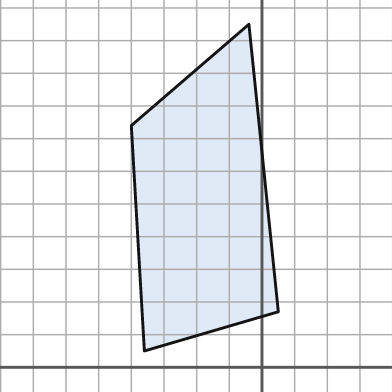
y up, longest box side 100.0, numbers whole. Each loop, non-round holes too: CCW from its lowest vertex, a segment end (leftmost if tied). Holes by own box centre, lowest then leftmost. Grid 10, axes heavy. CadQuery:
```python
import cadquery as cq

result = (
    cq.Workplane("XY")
    .moveTo(-36.0, 5.0)
    .lineTo(5.0, 17.0)
    .lineTo(-4.0, 105.0)
    .lineTo(-40.0, 74.0)
    .close()
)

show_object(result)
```